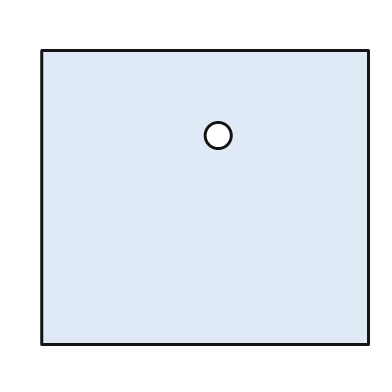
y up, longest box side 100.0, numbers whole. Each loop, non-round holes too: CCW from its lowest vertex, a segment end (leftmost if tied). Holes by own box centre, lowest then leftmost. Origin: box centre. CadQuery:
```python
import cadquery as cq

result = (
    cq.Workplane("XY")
    .moveTo(-50.0, -45.0)
    .lineTo(50.0, -45.0)
    .lineTo(50.0, 45.0)
    .lineTo(-50.0, 45.0)
    .close()
    .moveTo(4.0, 19.0)
    .circle(4.0)
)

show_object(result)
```